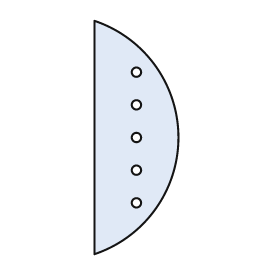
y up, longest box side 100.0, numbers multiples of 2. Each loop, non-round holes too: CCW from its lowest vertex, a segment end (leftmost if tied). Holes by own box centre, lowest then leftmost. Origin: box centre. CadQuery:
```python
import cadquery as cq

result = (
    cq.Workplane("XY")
    .moveTo(-18.0, -50.0)
    .threePointArc((18.0, 0.0), (-18.0, 50.0))
    .close()
    .moveTo(0.0, -28.0)
    .circle(2.0)
    .moveTo(0.0, -14.0)
    .circle(2.0)
    .moveTo(0.0, 0.0)
    .circle(2.0)
    .moveTo(0.0, 14.0)
    .circle(2.0)
    .moveTo(0.0, 28.0)
    .circle(2.0)
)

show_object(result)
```